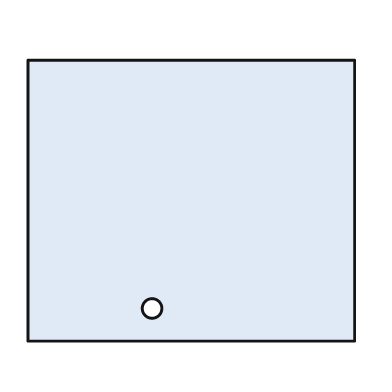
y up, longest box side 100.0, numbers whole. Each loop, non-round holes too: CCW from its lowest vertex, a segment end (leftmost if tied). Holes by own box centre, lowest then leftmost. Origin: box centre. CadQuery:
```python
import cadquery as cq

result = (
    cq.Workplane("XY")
    .moveTo(-50.0, -43.0)
    .lineTo(50.0, -43.0)
    .lineTo(50.0, 43.0)
    .lineTo(-50.0, 43.0)
    .close()
    .moveTo(-12.0, -33.0)
    .circle(3.0)
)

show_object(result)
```